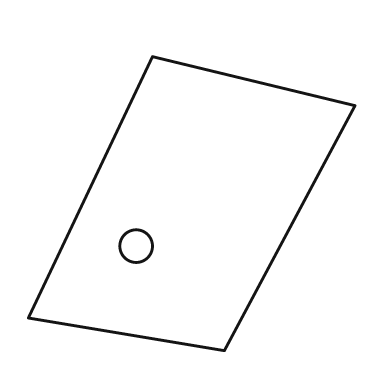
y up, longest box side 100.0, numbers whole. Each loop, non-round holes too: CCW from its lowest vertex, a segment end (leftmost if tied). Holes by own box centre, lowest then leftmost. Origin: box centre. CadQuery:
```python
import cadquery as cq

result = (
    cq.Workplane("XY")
    .moveTo(10.0, -45.0)
    .lineTo(50.0, 30.0)
    .lineTo(-12.0, 45.0)
    .lineTo(-50.0, -35.0)
    .close()
    .moveTo(-17.0, -13.0)
    .circle(5.0)
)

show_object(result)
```